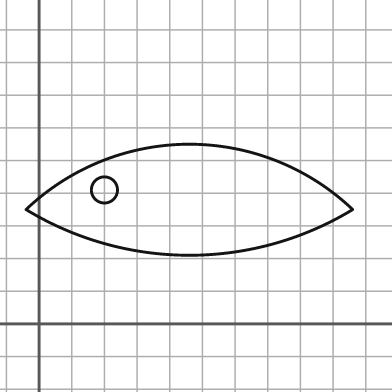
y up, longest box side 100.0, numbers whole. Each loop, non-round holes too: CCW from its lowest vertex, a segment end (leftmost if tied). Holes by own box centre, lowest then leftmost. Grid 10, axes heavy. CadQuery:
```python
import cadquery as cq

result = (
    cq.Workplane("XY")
    .moveTo(-4.0, 35.0)
    .threePointArc((46.0, 21.0), (96.0, 35.0))
    .threePointArc((46.0, 55.0), (-4.0, 35.0))
    .close()
    .moveTo(20.0, 41.0)
    .circle(4.0)
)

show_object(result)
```